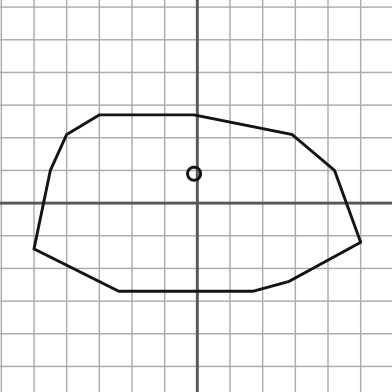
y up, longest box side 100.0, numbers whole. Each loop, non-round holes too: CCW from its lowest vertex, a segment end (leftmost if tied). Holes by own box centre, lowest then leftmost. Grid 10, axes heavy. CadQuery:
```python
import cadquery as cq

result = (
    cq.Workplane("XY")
    .moveTo(-24.0, -27.0)
    .lineTo(17.0, -27.0)
    .lineTo(28.0, -24.0)
    .lineTo(50.0, -12.0)
    .lineTo(42.0, 10.0)
    .lineTo(29.0, 21.0)
    .lineTo(-1.0, 27.0)
    .lineTo(-30.0, 27.0)
    .lineTo(-40.0, 21.0)
    .lineTo(-45.0, 10.0)
    .lineTo(-50.0, -14.0)
    .close()
    .moveTo(-1.0, 9.0)
    .circle(2.0)
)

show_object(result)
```